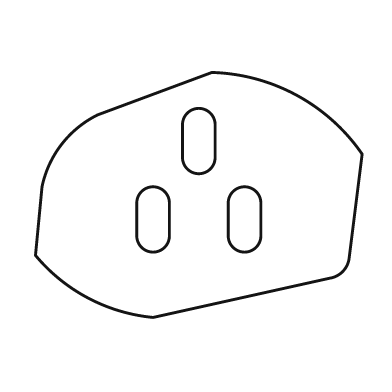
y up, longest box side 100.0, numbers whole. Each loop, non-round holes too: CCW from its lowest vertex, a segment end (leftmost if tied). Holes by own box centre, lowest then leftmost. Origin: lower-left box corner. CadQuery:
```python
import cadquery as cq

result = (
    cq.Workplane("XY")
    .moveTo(36.0, 0.0)
    .lineTo(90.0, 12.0)
    .threePointArc((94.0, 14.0), (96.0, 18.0))
    .lineTo(100.0, 50.0)
    .threePointArc((80.0, 68.0), (54.0, 75.0))
    .lineTo(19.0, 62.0)
    .threePointArc((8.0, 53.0), (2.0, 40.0))
    .lineTo(0.0, 19.0)
    .threePointArc((16.0, 6.0), (36.0, 0.0))
    .close()
    .moveTo(31.0, 25.0)
    .threePointArc((36.0, 20.0), (41.0, 25.0))
    .lineTo(41.0, 35.0)
    .threePointArc((36.0, 40.0), (31.0, 35.0))
    .close()
    .moveTo(59.0, 25.0)
    .threePointArc((64.0, 20.0), (69.0, 25.0))
    .lineTo(69.0, 35.0)
    .threePointArc((64.0, 40.0), (59.0, 35.0))
    .close()
    .moveTo(45.0, 49.0)
    .threePointArc((50.0, 44.0), (55.0, 49.0))
    .lineTo(55.0, 59.0)
    .threePointArc((50.0, 64.0), (45.0, 59.0))
    .close()
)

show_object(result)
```